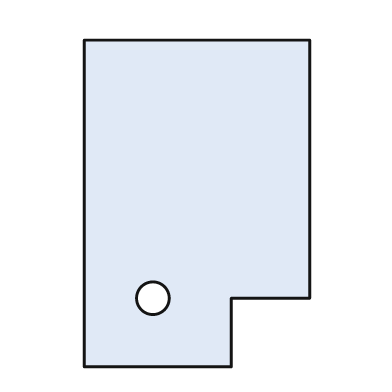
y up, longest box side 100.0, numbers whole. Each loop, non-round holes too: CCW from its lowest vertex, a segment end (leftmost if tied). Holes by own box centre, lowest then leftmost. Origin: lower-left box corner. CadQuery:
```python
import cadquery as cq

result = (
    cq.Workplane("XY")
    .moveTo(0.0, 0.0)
    .lineTo(45.0, 0.0)
    .lineTo(45.0, 21.0)
    .lineTo(69.0, 21.0)
    .lineTo(69.0, 100.0)
    .lineTo(0.0, 100.0)
    .close()
    .moveTo(21.0, 21.0)
    .circle(5.0)
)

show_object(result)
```